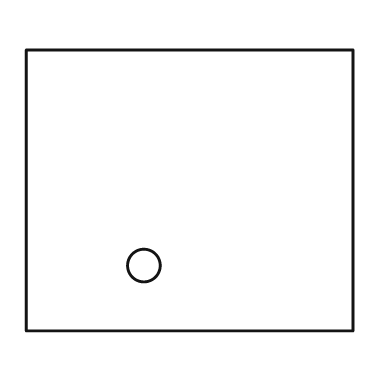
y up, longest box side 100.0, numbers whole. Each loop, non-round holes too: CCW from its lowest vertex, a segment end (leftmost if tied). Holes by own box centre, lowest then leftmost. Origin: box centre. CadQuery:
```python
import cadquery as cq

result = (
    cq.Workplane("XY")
    .moveTo(-50.0, -43.0)
    .lineTo(50.0, -43.0)
    .lineTo(50.0, 43.0)
    .lineTo(-50.0, 43.0)
    .close()
    .moveTo(-14.0, -23.0)
    .circle(5.0)
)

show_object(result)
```